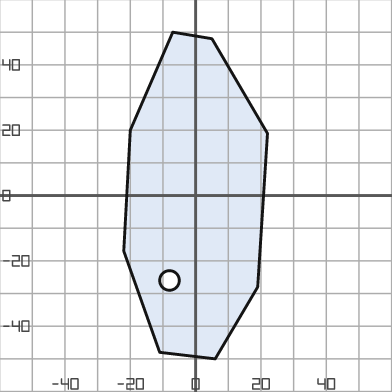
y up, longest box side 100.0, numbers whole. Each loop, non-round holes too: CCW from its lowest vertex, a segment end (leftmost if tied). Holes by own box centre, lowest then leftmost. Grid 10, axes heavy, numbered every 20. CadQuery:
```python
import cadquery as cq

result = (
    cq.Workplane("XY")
    .moveTo(6.0, -50.0)
    .lineTo(19.0, -28.0)
    .lineTo(22.0, 19.0)
    .lineTo(5.0, 48.0)
    .lineTo(-7.0, 50.0)
    .lineTo(-20.0, 20.0)
    .lineTo(-22.0, -17.0)
    .lineTo(-11.0, -48.0)
    .close()
    .moveTo(-8.0, -26.0)
    .circle(3.0)
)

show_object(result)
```